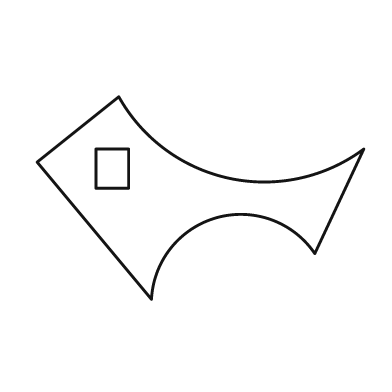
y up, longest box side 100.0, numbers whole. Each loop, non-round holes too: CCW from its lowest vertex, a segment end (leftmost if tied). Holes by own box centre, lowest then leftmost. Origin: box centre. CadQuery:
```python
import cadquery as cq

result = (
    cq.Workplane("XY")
    .moveTo(-15.0, -31.0)
    .threePointArc((5.0, -6.0), (35.0, -17.0))
    .lineTo(50.0, 15.0)
    .threePointArc((9.0, 6.0), (-25.0, 31.0))
    .lineTo(-50.0, 11.0)
    .close()
    .moveTo(-32.0, 3.0)
    .lineTo(-22.0, 3.0)
    .lineTo(-22.0, 15.0)
    .lineTo(-32.0, 15.0)
    .close()
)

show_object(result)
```